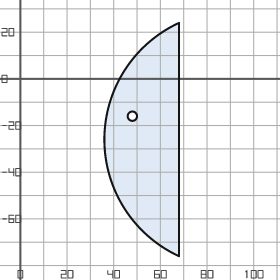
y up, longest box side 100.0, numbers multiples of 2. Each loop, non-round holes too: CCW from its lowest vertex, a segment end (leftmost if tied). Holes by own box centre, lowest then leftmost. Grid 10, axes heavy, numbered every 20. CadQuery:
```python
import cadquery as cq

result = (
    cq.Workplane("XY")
    .moveTo(68.0, -76.0)
    .lineTo(68.0, 24.0)
    .threePointArc((36.0, -26.0), (68.0, -76.0))
    .close()
    .moveTo(48.0, -16.0)
    .circle(2.0)
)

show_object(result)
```